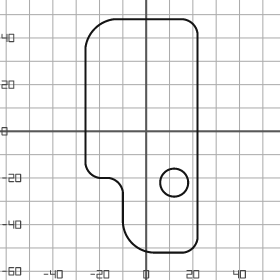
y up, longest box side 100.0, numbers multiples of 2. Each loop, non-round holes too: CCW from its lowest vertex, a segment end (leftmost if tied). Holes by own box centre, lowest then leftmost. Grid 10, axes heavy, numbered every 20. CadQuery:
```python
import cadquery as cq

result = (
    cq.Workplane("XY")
    .moveTo(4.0, -52.0)
    .lineTo(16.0, -52.0)
    .threePointArc((20.0, -50.0), (22.0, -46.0))
    .lineTo(22.0, 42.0)
    .threePointArc((20.0, 46.0), (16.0, 48.0))
    .lineTo(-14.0, 48.0)
    .threePointArc((-22.0, 44.0), (-26.0, 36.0))
    .lineTo(-26.0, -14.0)
    .threePointArc((-24.0, -18.0), (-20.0, -20.0))
    .lineTo(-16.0, -20.0)
    .threePointArc((-12.0, -22.0), (-10.0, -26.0))
    .lineTo(-10.0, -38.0)
    .threePointArc((-6.0, -48.0), (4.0, -52.0))
    .close()
    .moveTo(12.0, -22.0)
    .circle(6.0)
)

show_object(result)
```